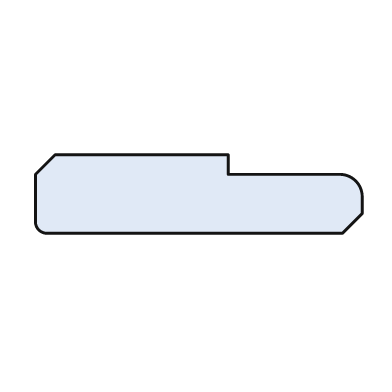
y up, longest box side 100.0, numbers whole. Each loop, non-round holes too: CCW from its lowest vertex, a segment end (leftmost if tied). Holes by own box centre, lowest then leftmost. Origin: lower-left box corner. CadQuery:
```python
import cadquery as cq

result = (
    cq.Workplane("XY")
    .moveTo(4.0, 0.0)
    .lineTo(94.0, 0.0)
    .lineTo(100.0, 6.0)
    .lineTo(100.0, 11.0)
    .threePointArc((98.0, 16.0), (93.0, 18.0))
    .lineTo(59.0, 18.0)
    .lineTo(59.0, 24.0)
    .lineTo(6.0, 24.0)
    .lineTo(0.0, 18.0)
    .lineTo(0.0, 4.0)
    .threePointArc((1.0, 1.0), (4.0, 0.0))
    .close()
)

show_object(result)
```